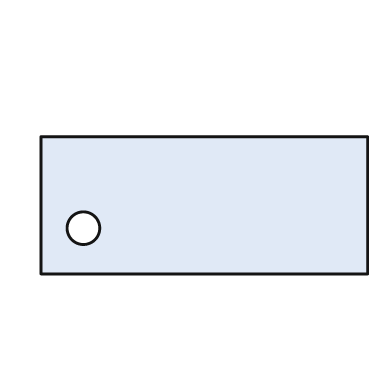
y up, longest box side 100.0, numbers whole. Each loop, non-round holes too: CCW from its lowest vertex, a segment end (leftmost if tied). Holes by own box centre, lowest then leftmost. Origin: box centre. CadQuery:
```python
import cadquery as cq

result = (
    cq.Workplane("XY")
    .moveTo(-50.0, -21.0)
    .lineTo(50.0, -21.0)
    .lineTo(50.0, 21.0)
    .lineTo(-50.0, 21.0)
    .close()
    .moveTo(-37.0, -7.0)
    .circle(5.0)
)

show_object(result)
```